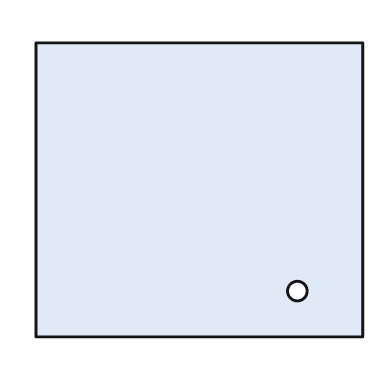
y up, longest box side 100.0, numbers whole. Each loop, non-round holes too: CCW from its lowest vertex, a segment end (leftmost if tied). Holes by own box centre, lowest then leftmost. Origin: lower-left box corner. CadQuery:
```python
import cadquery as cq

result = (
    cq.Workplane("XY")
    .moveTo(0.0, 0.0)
    .lineTo(100.0, 0.0)
    .lineTo(100.0, 90.0)
    .lineTo(0.0, 90.0)
    .close()
    .moveTo(80.0, 14.0)
    .circle(3.0)
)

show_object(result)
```